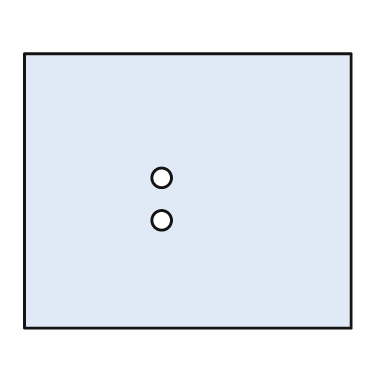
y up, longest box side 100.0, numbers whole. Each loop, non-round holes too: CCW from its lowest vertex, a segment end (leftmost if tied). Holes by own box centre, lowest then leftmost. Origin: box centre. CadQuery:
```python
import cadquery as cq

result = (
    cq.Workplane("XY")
    .moveTo(-50.0, -42.0)
    .lineTo(50.0, -42.0)
    .lineTo(50.0, 42.0)
    .lineTo(-50.0, 42.0)
    .close()
    .moveTo(-8.0, -9.0)
    .circle(3.0)
    .moveTo(-8.0, 4.0)
    .circle(3.0)
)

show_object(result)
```